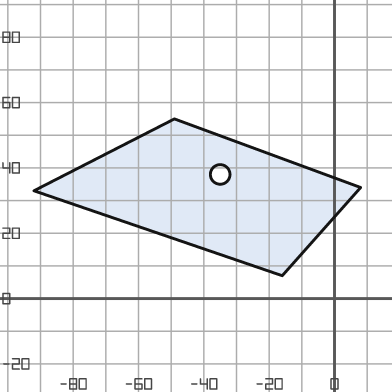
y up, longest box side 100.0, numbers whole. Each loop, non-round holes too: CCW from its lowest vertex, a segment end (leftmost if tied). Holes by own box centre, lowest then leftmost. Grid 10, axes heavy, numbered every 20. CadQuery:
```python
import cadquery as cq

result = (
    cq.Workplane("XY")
    .moveTo(-16.0, 7.0)
    .lineTo(8.0, 34.0)
    .lineTo(-49.0, 55.0)
    .lineTo(-92.0, 33.0)
    .close()
    .moveTo(-35.0, 38.0)
    .circle(3.0)
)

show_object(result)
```